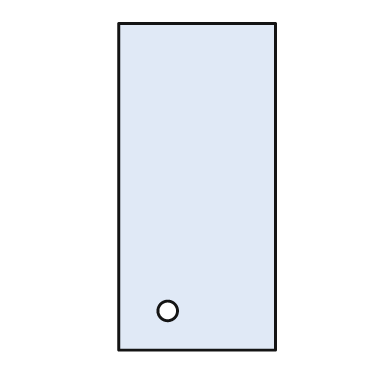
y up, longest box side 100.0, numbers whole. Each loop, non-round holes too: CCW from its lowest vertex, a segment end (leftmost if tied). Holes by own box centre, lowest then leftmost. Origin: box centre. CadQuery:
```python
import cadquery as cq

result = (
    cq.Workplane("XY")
    .moveTo(-24.0, -50.0)
    .lineTo(24.0, -50.0)
    .lineTo(24.0, 50.0)
    .lineTo(-24.0, 50.0)
    .close()
    .moveTo(-9.0, -38.0)
    .circle(3.0)
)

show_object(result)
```